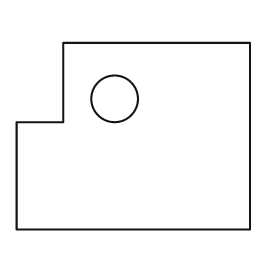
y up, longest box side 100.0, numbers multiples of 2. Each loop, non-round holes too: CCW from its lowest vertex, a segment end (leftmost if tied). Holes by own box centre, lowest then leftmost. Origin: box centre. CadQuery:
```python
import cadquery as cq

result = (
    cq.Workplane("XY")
    .moveTo(-50.0, -40.0)
    .lineTo(50.0, -40.0)
    .lineTo(50.0, 40.0)
    .lineTo(-30.0, 40.0)
    .lineTo(-30.0, 6.0)
    .lineTo(-50.0, 6.0)
    .close()
    .moveTo(-8.0, 16.0)
    .circle(10.0)
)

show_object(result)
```